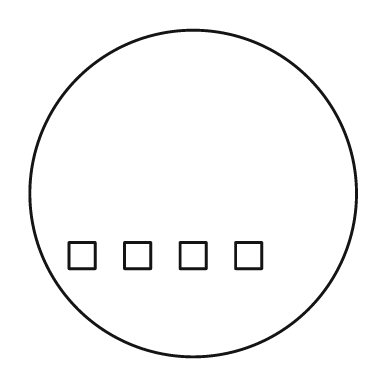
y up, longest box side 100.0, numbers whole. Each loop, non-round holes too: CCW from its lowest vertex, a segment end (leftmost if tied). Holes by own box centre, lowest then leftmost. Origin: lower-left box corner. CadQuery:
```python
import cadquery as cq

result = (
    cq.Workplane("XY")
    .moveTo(50.0, 50.0)
    .circle(50.0)
    .moveTo(12.0, 27.0)
    .lineTo(20.0, 27.0)
    .lineTo(20.0, 35.0)
    .lineTo(12.0, 35.0)
    .close()
    .moveTo(29.0, 27.0)
    .lineTo(37.0, 27.0)
    .lineTo(37.0, 35.0)
    .lineTo(29.0, 35.0)
    .close()
    .moveTo(46.0, 27.0)
    .lineTo(54.0, 27.0)
    .lineTo(54.0, 35.0)
    .lineTo(46.0, 35.0)
    .close()
    .moveTo(63.0, 27.0)
    .lineTo(71.0, 27.0)
    .lineTo(71.0, 35.0)
    .lineTo(63.0, 35.0)
    .close()
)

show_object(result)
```